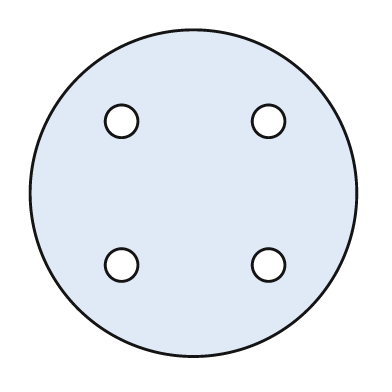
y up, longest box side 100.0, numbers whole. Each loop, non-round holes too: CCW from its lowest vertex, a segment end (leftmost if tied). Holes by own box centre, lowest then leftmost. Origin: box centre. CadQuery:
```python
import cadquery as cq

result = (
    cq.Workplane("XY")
    .moveTo(0.0, 0.0)
    .circle(50.0)
    .moveTo(-22.0, -22.0)
    .circle(5.0)
    .moveTo(23.0, -22.0)
    .circle(5.0)
    .moveTo(-22.0, 22.0)
    .circle(5.0)
    .moveTo(23.0, 22.0)
    .circle(5.0)
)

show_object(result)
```